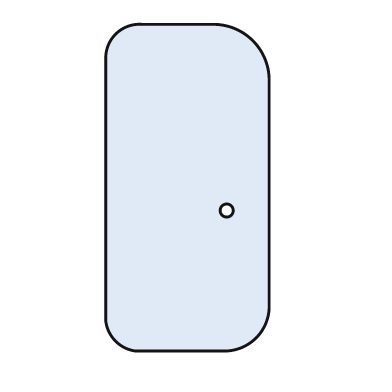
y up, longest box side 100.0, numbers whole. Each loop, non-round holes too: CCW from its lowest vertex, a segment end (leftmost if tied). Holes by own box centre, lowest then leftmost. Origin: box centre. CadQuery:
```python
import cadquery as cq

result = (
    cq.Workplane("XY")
    .moveTo(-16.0, -50.0)
    .lineTo(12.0, -50.0)
    .threePointArc((21.0, -46.0), (25.0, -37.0))
    .lineTo(25.0, 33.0)
    .threePointArc((20.0, 45.0), (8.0, 50.0))
    .lineTo(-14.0, 50.0)
    .threePointArc((-22.0, 47.0), (-25.0, 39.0))
    .lineTo(-25.0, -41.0)
    .threePointArc((-22.0, -47.0), (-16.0, -50.0))
    .close()
    .moveTo(12.0, -7.0)
    .circle(2.0)
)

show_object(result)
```